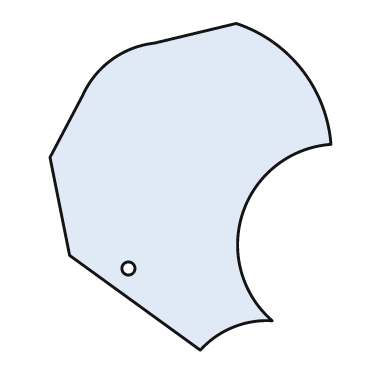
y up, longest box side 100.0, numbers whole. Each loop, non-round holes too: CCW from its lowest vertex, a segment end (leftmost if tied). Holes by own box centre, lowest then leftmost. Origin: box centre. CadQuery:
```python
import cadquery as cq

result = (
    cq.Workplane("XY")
    .moveTo(3.0, -50.0)
    .threePointArc((13.0, -43.0), (25.0, -41.0))
    .threePointArc((16.0, -8.0), (43.0, 13.0))
    .threePointArc((34.0, 36.0), (14.0, 50.0))
    .lineTo(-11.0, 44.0)
    .threePointArc((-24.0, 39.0), (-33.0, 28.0))
    .lineTo(-43.0, 9.0)
    .lineTo(-37.0, -21.0)
    .close()
    .moveTo(-19.0, -25.0)
    .circle(2.0)
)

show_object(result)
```